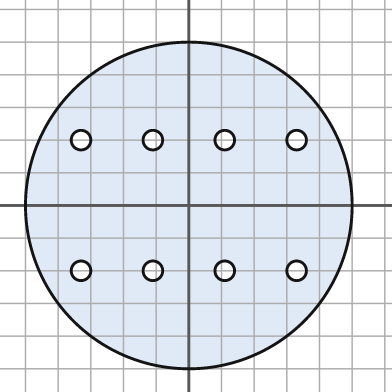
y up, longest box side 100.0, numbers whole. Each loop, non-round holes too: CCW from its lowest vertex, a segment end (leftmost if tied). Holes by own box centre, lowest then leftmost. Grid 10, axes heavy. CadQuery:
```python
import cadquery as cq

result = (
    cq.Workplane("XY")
    .moveTo(0.0, 0.0)
    .circle(50.0)
    .moveTo(-33.0, -20.0)
    .circle(3.0)
    .moveTo(-11.0, -20.0)
    .circle(3.0)
    .moveTo(11.0, -20.0)
    .circle(3.0)
    .moveTo(33.0, -20.0)
    .circle(3.0)
    .moveTo(-33.0, 20.0)
    .circle(3.0)
    .moveTo(-11.0, 20.0)
    .circle(3.0)
    .moveTo(11.0, 20.0)
    .circle(3.0)
    .moveTo(33.0, 20.0)
    .circle(3.0)
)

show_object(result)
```